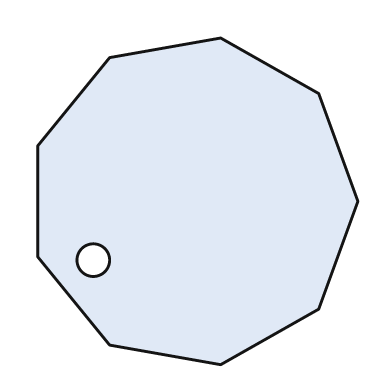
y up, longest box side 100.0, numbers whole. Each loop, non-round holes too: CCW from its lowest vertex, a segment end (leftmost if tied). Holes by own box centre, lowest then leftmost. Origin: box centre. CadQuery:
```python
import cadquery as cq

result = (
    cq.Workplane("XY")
    .moveTo(7.0, -50.0)
    .lineTo(37.0, -33.0)
    .lineTo(49.0, 0.0)
    .lineTo(37.0, 33.0)
    .lineTo(7.0, 50.0)
    .lineTo(-27.0, 44.0)
    .lineTo(-49.0, 17.0)
    .lineTo(-49.0, -17.0)
    .lineTo(-27.0, -44.0)
    .close()
    .moveTo(-32.0, -18.0)
    .circle(5.0)
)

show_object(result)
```